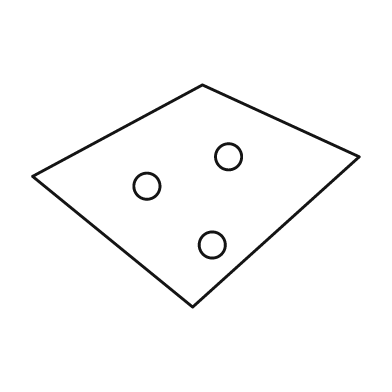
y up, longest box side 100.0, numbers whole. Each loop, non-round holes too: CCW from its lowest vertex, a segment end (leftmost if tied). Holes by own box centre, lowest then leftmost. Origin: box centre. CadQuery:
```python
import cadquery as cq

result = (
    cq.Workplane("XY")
    .moveTo(-1.0, -34.0)
    .lineTo(50.0, 12.0)
    .lineTo(2.0, 34.0)
    .lineTo(-50.0, 6.0)
    .close()
    .moveTo(5.0, -15.0)
    .circle(4.0)
    .moveTo(-15.0, 3.0)
    .circle(4.0)
    .moveTo(10.0, 12.0)
    .circle(4.0)
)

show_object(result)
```